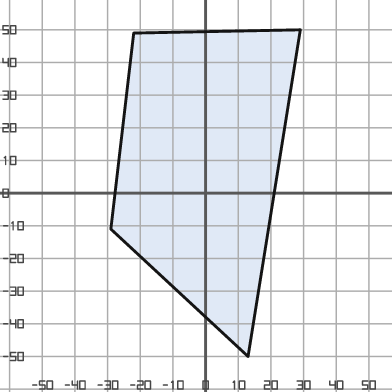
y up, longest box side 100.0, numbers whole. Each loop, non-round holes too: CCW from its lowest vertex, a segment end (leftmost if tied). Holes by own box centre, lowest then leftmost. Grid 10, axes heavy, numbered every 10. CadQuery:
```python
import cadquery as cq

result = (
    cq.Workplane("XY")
    .moveTo(13.0, -50.0)
    .lineTo(29.0, 50.0)
    .lineTo(-22.0, 49.0)
    .lineTo(-29.0, -11.0)
    .close()
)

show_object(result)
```